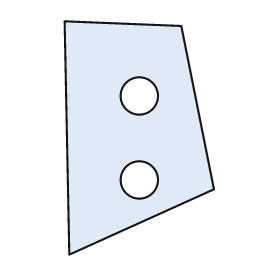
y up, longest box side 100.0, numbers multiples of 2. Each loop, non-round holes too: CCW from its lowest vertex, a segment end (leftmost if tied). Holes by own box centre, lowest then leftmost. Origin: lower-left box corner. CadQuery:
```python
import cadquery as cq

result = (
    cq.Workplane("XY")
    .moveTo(2.0, 0.0)
    .lineTo(64.0, 28.0)
    .lineTo(50.0, 98.0)
    .lineTo(0.0, 100.0)
    .close()
    .moveTo(32.0, 32.0)
    .circle(8.0)
    .moveTo(32.0, 68.0)
    .circle(8.0)
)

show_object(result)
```